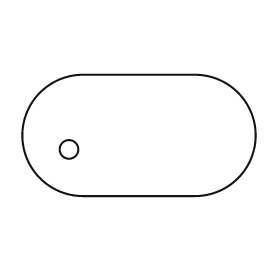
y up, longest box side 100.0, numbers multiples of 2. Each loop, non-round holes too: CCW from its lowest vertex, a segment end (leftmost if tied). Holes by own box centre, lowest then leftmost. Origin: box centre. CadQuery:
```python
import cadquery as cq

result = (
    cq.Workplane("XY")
    .moveTo(-24.0, -26.0)
    .lineTo(24.0, -26.0)
    .threePointArc((50.0, 0.0), (24.0, 26.0))
    .lineTo(-24.0, 26.0)
    .threePointArc((-50.0, 0.0), (-24.0, -26.0))
    .close()
    .moveTo(-30.0, -6.0)
    .circle(4.0)
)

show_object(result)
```